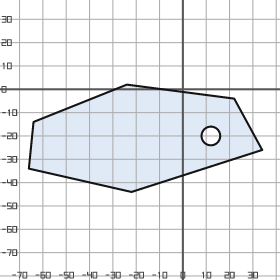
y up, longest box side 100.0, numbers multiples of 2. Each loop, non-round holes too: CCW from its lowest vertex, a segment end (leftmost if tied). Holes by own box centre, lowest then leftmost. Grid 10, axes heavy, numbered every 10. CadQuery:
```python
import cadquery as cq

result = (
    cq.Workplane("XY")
    .moveTo(-22.0, -44.0)
    .lineTo(34.0, -26.0)
    .lineTo(22.0, -4.0)
    .lineTo(-24.0, 2.0)
    .lineTo(-64.0, -14.0)
    .lineTo(-66.0, -34.0)
    .close()
    .moveTo(12.0, -20.0)
    .circle(4.0)
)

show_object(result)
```